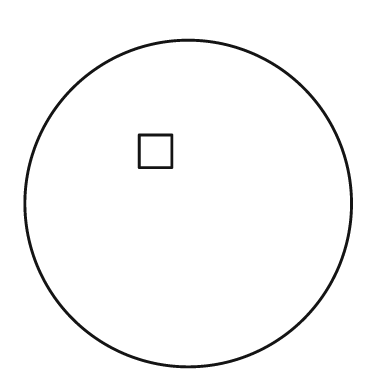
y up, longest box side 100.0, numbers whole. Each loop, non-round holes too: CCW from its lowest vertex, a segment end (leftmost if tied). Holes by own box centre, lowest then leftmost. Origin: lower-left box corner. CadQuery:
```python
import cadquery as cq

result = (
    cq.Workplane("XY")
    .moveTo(50.0, 50.0)
    .circle(50.0)
    .moveTo(35.0, 61.0)
    .lineTo(45.0, 61.0)
    .lineTo(45.0, 71.0)
    .lineTo(35.0, 71.0)
    .close()
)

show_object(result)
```